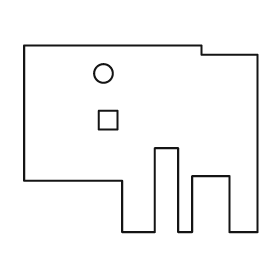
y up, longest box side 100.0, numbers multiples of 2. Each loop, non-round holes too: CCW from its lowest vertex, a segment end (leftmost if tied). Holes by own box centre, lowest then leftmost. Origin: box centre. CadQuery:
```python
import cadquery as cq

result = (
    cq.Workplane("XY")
    .moveTo(-8.0, -40.0)
    .lineTo(6.0, -40.0)
    .lineTo(6.0, -4.0)
    .lineTo(16.0, -4.0)
    .lineTo(16.0, -40.0)
    .lineTo(22.0, -40.0)
    .lineTo(22.0, -16.0)
    .lineTo(38.0, -16.0)
    .lineTo(38.0, -40.0)
    .lineTo(50.0, -40.0)
    .lineTo(50.0, 36.0)
    .lineTo(26.0, 36.0)
    .lineTo(26.0, 40.0)
    .lineTo(-50.0, 40.0)
    .lineTo(-50.0, -18.0)
    .lineTo(-8.0, -18.0)
    .close()
    .moveTo(-18.0, 4.0)
    .lineTo(-10.0, 4.0)
    .lineTo(-10.0, 12.0)
    .lineTo(-18.0, 12.0)
    .close()
    .moveTo(-16.0, 28.0)
    .circle(4.0)
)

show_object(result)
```